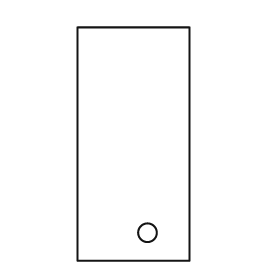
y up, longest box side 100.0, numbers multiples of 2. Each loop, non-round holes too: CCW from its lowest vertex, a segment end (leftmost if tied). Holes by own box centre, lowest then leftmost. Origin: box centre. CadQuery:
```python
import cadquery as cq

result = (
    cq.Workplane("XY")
    .moveTo(-24.0, -50.0)
    .lineTo(24.0, -50.0)
    .lineTo(24.0, 50.0)
    .lineTo(-24.0, 50.0)
    .close()
    .moveTo(6.0, -38.0)
    .circle(4.0)
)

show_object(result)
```